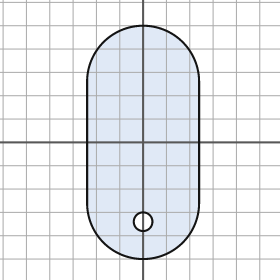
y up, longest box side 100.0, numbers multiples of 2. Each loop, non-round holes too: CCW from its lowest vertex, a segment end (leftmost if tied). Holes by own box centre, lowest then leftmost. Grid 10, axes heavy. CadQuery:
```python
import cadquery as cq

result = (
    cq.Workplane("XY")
    .moveTo(-24.0, -26.0)
    .threePointArc((0.0, -50.0), (24.0, -26.0))
    .lineTo(24.0, 26.0)
    .threePointArc((0.0, 50.0), (-24.0, 26.0))
    .close()
    .moveTo(0.0, -34.0)
    .circle(4.0)
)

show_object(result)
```